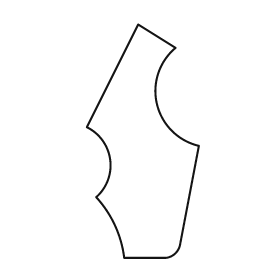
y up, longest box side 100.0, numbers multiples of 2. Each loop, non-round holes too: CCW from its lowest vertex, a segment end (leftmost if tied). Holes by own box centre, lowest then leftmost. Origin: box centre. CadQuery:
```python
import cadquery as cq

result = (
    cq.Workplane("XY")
    .moveTo(-8.0, -50.0)
    .lineTo(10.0, -50.0)
    .threePointArc((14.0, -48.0), (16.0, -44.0))
    .lineTo(24.0, -2.0)
    .threePointArc((6.0, 16.0), (14.0, 40.0))
    .lineTo(-2.0, 50.0)
    .lineTo(-24.0, 6.0)
    .threePointArc((-14.0, -8.0), (-20.0, -24.0))
    .threePointArc((-12.0, -36.0), (-8.0, -50.0))
    .close()
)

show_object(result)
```